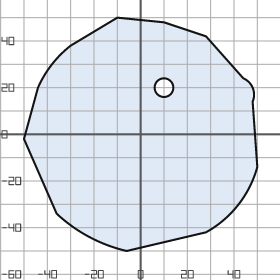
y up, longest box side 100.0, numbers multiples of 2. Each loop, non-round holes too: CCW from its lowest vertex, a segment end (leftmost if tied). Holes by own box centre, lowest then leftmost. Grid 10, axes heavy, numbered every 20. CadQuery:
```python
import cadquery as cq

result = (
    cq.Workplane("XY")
    .moveTo(-6.0, -50.0)
    .lineTo(28.0, -42.0)
    .threePointArc((42.0, -30.0), (50.0, -14.0))
    .lineTo(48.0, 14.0)
    .threePointArc((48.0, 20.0), (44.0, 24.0))
    .lineTo(28.0, 42.0)
    .lineTo(10.0, 48.0)
    .lineTo(-10.0, 50.0)
    .lineTo(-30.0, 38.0)
    .threePointArc((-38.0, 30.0), (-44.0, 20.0))
    .lineTo(-50.0, -2.0)
    .lineTo(-36.0, -34.0)
    .threePointArc((-22.0, -44.0), (-6.0, -50.0))
    .close()
    .moveTo(10.0, 20.0)
    .circle(4.0)
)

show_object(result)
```